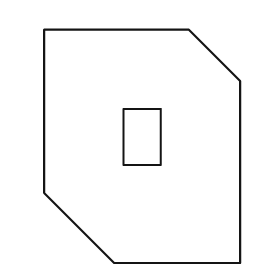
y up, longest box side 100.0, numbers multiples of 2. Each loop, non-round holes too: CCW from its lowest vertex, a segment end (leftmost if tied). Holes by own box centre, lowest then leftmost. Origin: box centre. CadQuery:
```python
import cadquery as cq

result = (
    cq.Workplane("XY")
    .moveTo(-12.0, -50.0)
    .lineTo(42.0, -50.0)
    .lineTo(42.0, 28.0)
    .lineTo(20.0, 50.0)
    .lineTo(-42.0, 50.0)
    .lineTo(-42.0, -20.0)
    .close()
    .moveTo(-8.0, -8.0)
    .lineTo(8.0, -8.0)
    .lineTo(8.0, 16.0)
    .lineTo(-8.0, 16.0)
    .close()
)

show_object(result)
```